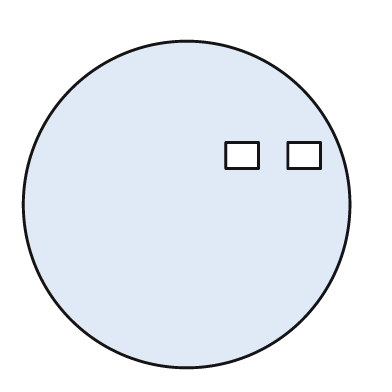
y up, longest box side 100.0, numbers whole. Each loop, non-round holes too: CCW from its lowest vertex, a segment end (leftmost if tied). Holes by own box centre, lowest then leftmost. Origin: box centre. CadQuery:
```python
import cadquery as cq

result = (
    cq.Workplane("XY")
    .moveTo(0.0, 0.0)
    .circle(50.0)
    .moveTo(12.0, 11.0)
    .lineTo(22.0, 11.0)
    .lineTo(22.0, 19.0)
    .lineTo(12.0, 19.0)
    .close()
    .moveTo(31.0, 11.0)
    .lineTo(41.0, 11.0)
    .lineTo(41.0, 19.0)
    .lineTo(31.0, 19.0)
    .close()
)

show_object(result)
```